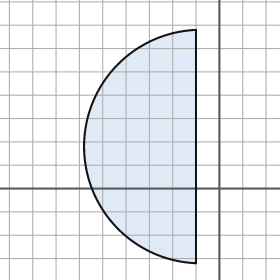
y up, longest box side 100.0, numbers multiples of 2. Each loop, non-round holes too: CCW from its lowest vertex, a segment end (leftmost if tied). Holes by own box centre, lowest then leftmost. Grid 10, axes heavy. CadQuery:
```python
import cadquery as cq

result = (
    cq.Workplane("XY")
    .moveTo(-10.0, -32.0)
    .lineTo(-10.0, 68.0)
    .threePointArc((-58.0, 18.0), (-10.0, -32.0))
    .close()
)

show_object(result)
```